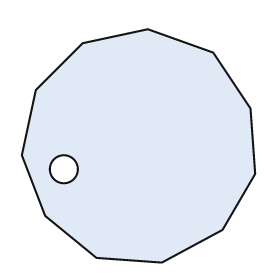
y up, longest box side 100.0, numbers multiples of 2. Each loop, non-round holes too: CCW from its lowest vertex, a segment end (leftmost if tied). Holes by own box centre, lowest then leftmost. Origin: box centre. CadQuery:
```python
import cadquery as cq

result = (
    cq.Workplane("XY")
    .moveTo(10.0, -50.0)
    .lineTo(36.0, -36.0)
    .lineTo(50.0, -12.0)
    .lineTo(48.0, 16.0)
    .lineTo(32.0, 40.0)
    .lineTo(4.0, 50.0)
    .lineTo(-24.0, 44.0)
    .lineTo(-44.0, 24.0)
    .lineTo(-50.0, -4.0)
    .lineTo(-40.0, -30.0)
    .lineTo(-18.0, -48.0)
    .close()
    .moveTo(-32.0, -10.0)
    .circle(6.0)
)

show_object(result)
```